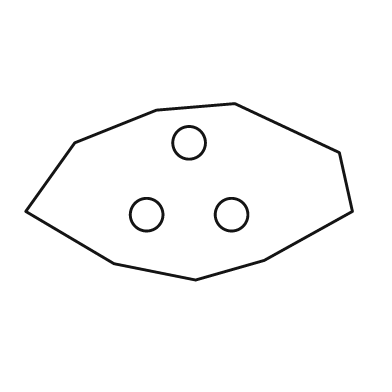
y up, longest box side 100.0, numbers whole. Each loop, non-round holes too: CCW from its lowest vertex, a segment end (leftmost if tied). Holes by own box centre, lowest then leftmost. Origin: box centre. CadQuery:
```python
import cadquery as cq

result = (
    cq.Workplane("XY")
    .moveTo(2.0, -27.0)
    .lineTo(23.0, -21.0)
    .lineTo(50.0, -6.0)
    .lineTo(46.0, 12.0)
    .lineTo(14.0, 27.0)
    .lineTo(-10.0, 25.0)
    .lineTo(-35.0, 15.0)
    .lineTo(-50.0, -6.0)
    .lineTo(-23.0, -22.0)
    .close()
    .moveTo(-13.0, -7.0)
    .circle(5.0)
    .moveTo(13.0, -7.0)
    .circle(5.0)
    .moveTo(0.0, 15.0)
    .circle(5.0)
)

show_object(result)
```